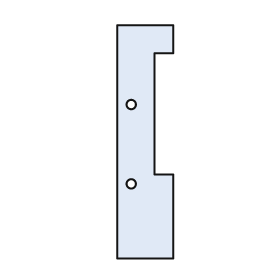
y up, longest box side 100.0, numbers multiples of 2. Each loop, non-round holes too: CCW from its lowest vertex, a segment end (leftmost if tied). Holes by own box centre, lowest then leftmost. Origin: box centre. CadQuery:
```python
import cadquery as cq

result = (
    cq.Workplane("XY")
    .moveTo(-12.0, -50.0)
    .lineTo(12.0, -50.0)
    .lineTo(12.0, -14.0)
    .lineTo(4.0, -14.0)
    .lineTo(4.0, 38.0)
    .lineTo(12.0, 38.0)
    .lineTo(12.0, 50.0)
    .lineTo(-12.0, 50.0)
    .close()
    .moveTo(-6.0, -18.0)
    .circle(2.0)
    .moveTo(-6.0, 16.0)
    .circle(2.0)
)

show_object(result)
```